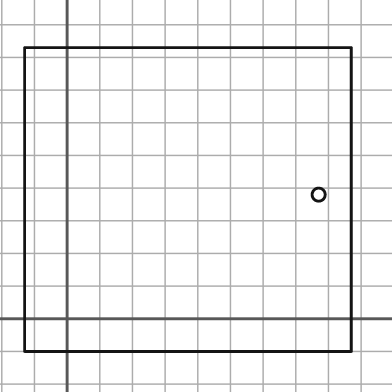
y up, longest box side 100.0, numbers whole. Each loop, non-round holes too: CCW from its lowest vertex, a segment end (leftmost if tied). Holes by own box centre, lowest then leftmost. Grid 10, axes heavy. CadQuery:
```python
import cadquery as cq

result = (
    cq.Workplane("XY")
    .moveTo(-13.0, -10.0)
    .lineTo(87.0, -10.0)
    .lineTo(87.0, 83.0)
    .lineTo(-13.0, 83.0)
    .close()
    .moveTo(77.0, 38.0)
    .circle(2.0)
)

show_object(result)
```